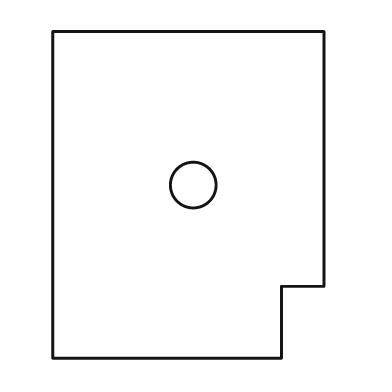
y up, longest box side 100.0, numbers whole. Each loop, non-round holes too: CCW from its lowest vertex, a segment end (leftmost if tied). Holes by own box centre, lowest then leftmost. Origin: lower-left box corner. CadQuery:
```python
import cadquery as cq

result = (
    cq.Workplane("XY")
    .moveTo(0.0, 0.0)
    .lineTo(70.0, 0.0)
    .lineTo(70.0, 22.0)
    .lineTo(83.0, 22.0)
    .lineTo(83.0, 100.0)
    .lineTo(0.0, 100.0)
    .close()
    .moveTo(43.0, 53.0)
    .circle(7.0)
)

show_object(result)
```